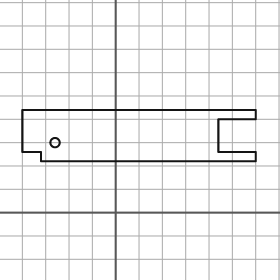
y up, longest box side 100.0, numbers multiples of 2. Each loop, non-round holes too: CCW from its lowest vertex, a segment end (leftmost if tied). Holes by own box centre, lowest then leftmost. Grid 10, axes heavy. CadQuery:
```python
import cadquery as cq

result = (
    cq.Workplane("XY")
    .moveTo(-32.0, 22.0)
    .lineTo(60.0, 22.0)
    .lineTo(60.0, 26.0)
    .lineTo(44.0, 26.0)
    .lineTo(44.0, 40.0)
    .lineTo(60.0, 40.0)
    .lineTo(60.0, 44.0)
    .lineTo(-40.0, 44.0)
    .lineTo(-40.0, 26.0)
    .lineTo(-32.0, 26.0)
    .close()
    .moveTo(-26.0, 30.0)
    .circle(2.0)
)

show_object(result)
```